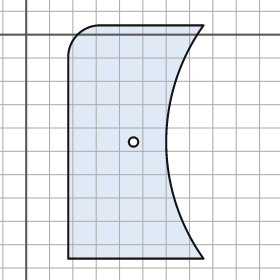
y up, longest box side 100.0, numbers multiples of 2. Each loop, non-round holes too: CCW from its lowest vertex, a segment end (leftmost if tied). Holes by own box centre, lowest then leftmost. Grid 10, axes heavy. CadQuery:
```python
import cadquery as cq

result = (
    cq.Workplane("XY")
    .moveTo(18.0, -96.0)
    .lineTo(76.0, -96.0)
    .threePointArc((60.0, -46.0), (76.0, 4.0))
    .lineTo(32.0, 4.0)
    .threePointArc((22.0, 0.0), (18.0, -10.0))
    .close()
    .moveTo(46.0, -46.0)
    .circle(2.0)
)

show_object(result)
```